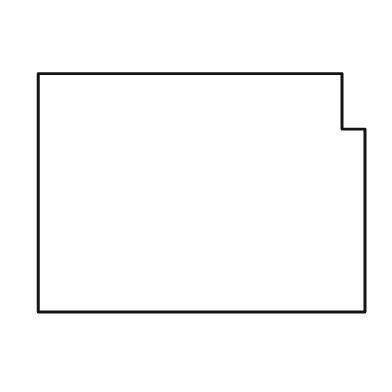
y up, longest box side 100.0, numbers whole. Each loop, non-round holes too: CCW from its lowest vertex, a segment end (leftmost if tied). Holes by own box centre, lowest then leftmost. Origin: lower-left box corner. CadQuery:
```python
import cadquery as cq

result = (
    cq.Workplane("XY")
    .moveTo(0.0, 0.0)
    .lineTo(100.0, 0.0)
    .lineTo(100.0, 56.0)
    .lineTo(93.0, 56.0)
    .lineTo(93.0, 73.0)
    .lineTo(0.0, 73.0)
    .close()
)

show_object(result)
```